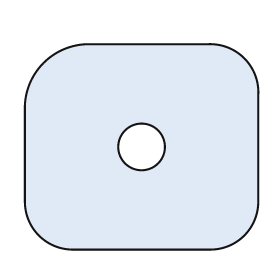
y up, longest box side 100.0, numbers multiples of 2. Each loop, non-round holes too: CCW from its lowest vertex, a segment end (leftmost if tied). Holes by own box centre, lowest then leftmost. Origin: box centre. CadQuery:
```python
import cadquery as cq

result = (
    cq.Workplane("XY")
    .moveTo(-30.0, -44.0)
    .lineTo(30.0, -44.0)
    .threePointArc((44.0, -38.0), (50.0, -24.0))
    .lineTo(50.0, 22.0)
    .threePointArc((44.0, 38.0), (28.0, 44.0))
    .lineTo(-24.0, 44.0)
    .threePointArc((-42.0, 36.0), (-50.0, 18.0))
    .lineTo(-50.0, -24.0)
    .threePointArc((-44.0, -38.0), (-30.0, -44.0))
    .close()
    .moveTo(0.0, 0.0)
    .circle(10.0)
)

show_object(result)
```